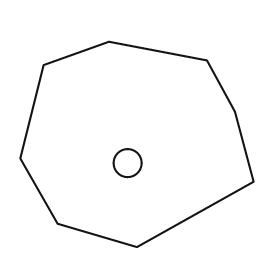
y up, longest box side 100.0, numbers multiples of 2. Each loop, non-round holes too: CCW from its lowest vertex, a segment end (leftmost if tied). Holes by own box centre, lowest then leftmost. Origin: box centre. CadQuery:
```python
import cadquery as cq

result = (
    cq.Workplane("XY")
    .moveTo(0.0, -44.0)
    .lineTo(50.0, -16.0)
    .lineTo(42.0, 14.0)
    .lineTo(30.0, 36.0)
    .lineTo(-12.0, 44.0)
    .lineTo(-40.0, 34.0)
    .lineTo(-50.0, -6.0)
    .lineTo(-34.0, -34.0)
    .close()
    .moveTo(-4.0, -8.0)
    .circle(6.0)
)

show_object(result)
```